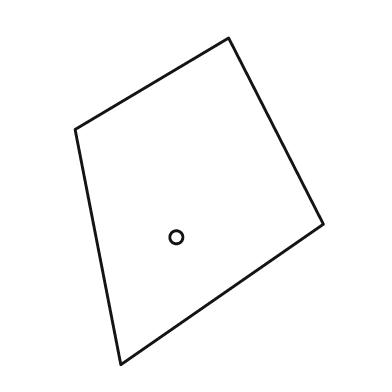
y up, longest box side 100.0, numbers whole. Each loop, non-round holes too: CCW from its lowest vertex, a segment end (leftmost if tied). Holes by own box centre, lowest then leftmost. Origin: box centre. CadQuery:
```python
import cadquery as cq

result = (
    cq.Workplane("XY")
    .moveTo(-24.0, -50.0)
    .lineTo(38.0, -7.0)
    .lineTo(9.0, 50.0)
    .lineTo(-38.0, 22.0)
    .close()
    .moveTo(-7.0, -11.0)
    .circle(2.0)
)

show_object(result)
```